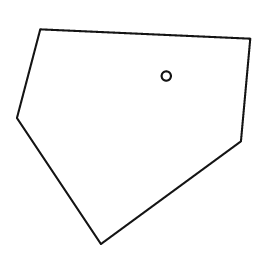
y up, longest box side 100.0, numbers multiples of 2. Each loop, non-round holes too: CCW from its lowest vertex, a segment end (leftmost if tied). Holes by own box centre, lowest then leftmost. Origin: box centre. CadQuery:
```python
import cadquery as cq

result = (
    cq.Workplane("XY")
    .moveTo(-14.0, -46.0)
    .lineTo(46.0, -2.0)
    .lineTo(50.0, 42.0)
    .lineTo(-40.0, 46.0)
    .lineTo(-50.0, 8.0)
    .close()
    .moveTo(14.0, 26.0)
    .circle(2.0)
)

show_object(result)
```